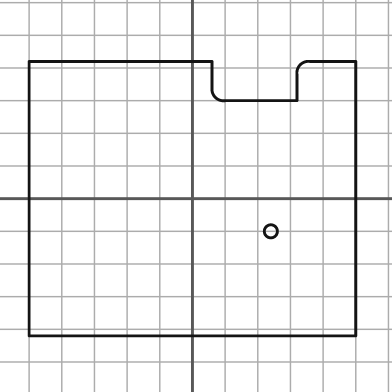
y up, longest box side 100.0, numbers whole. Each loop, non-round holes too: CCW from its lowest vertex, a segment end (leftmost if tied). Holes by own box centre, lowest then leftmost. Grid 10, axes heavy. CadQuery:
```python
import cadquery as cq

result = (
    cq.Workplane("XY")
    .moveTo(-50.0, -42.0)
    .lineTo(50.0, -42.0)
    .lineTo(50.0, 42.0)
    .lineTo(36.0, 42.0)
    .threePointArc((33.0, 41.0), (32.0, 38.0))
    .lineTo(32.0, 30.0)
    .lineTo(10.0, 30.0)
    .threePointArc((7.0, 31.0), (6.0, 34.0))
    .lineTo(6.0, 42.0)
    .lineTo(-50.0, 42.0)
    .close()
    .moveTo(24.0, -10.0)
    .circle(2.0)
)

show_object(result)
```